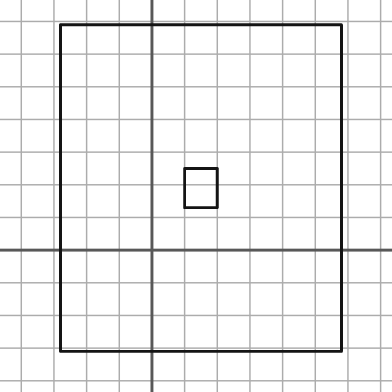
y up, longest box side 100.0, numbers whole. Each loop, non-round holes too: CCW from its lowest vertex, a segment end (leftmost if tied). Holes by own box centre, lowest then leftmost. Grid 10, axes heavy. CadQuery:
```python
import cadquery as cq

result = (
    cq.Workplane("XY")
    .moveTo(-28.0, -31.0)
    .lineTo(58.0, -31.0)
    .lineTo(58.0, 69.0)
    .lineTo(-28.0, 69.0)
    .close()
    .moveTo(10.0, 13.0)
    .lineTo(20.0, 13.0)
    .lineTo(20.0, 25.0)
    .lineTo(10.0, 25.0)
    .close()
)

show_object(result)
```